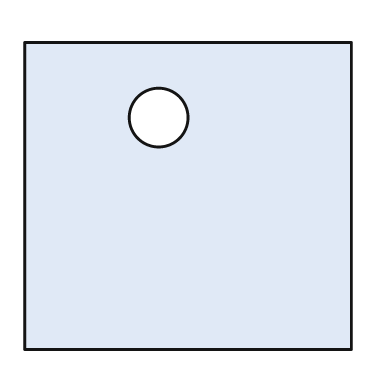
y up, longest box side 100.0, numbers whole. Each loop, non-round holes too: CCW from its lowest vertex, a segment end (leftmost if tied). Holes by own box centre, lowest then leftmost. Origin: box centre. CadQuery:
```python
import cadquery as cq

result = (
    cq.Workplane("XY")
    .moveTo(-50.0, -47.0)
    .lineTo(50.0, -47.0)
    .lineTo(50.0, 47.0)
    .lineTo(-50.0, 47.0)
    .close()
    .moveTo(-9.0, 24.0)
    .circle(9.0)
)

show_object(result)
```